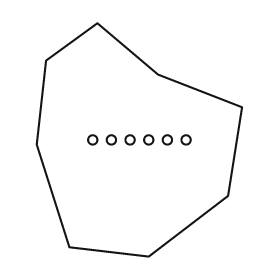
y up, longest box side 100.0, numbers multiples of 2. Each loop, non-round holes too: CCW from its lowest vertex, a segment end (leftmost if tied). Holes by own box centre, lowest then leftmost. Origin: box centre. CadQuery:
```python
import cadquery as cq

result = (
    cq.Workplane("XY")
    .moveTo(4.0, -50.0)
    .lineTo(38.0, -24.0)
    .lineTo(44.0, 14.0)
    .lineTo(8.0, 28.0)
    .lineTo(-18.0, 50.0)
    .lineTo(-40.0, 34.0)
    .lineTo(-44.0, -2.0)
    .lineTo(-30.0, -46.0)
    .close()
    .moveTo(-20.0, 0.0)
    .circle(2.0)
    .moveTo(-12.0, 0.0)
    .circle(2.0)
    .moveTo(-4.0, 0.0)
    .circle(2.0)
    .moveTo(4.0, 0.0)
    .circle(2.0)
    .moveTo(12.0, 0.0)
    .circle(2.0)
    .moveTo(20.0, 0.0)
    .circle(2.0)
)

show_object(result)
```